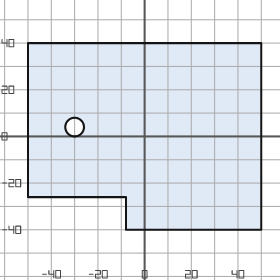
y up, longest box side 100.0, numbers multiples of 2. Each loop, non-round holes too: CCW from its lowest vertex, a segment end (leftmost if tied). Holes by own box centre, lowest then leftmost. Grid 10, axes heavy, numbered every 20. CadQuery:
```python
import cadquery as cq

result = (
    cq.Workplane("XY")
    .moveTo(-8.0, -40.0)
    .lineTo(50.0, -40.0)
    .lineTo(50.0, 40.0)
    .lineTo(-50.0, 40.0)
    .lineTo(-50.0, -26.0)
    .lineTo(-8.0, -26.0)
    .close()
    .moveTo(-30.0, 4.0)
    .circle(4.0)
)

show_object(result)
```